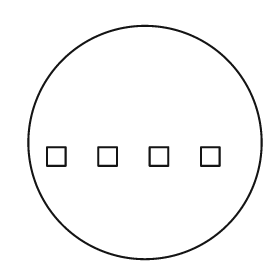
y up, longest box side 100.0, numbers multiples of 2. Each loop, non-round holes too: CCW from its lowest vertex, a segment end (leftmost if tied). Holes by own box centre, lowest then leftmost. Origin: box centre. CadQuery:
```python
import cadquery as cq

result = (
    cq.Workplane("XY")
    .moveTo(0.0, 0.0)
    .circle(50.0)
    .moveTo(-42.0, -10.0)
    .lineTo(-34.0, -10.0)
    .lineTo(-34.0, -2.0)
    .lineTo(-42.0, -2.0)
    .close()
    .moveTo(-20.0, -10.0)
    .lineTo(-12.0, -10.0)
    .lineTo(-12.0, -2.0)
    .lineTo(-20.0, -2.0)
    .close()
    .moveTo(2.0, -10.0)
    .lineTo(10.0, -10.0)
    .lineTo(10.0, -2.0)
    .lineTo(2.0, -2.0)
    .close()
    .moveTo(24.0, -10.0)
    .lineTo(32.0, -10.0)
    .lineTo(32.0, -2.0)
    .lineTo(24.0, -2.0)
    .close()
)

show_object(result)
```